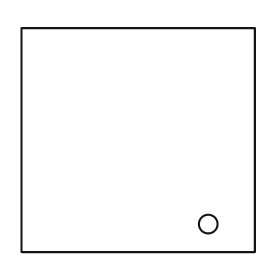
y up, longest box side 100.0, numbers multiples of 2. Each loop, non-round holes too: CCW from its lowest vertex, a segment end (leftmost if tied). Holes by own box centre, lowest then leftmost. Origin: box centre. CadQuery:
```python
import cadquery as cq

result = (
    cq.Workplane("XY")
    .moveTo(-50.0, -48.0)
    .lineTo(50.0, -48.0)
    .lineTo(50.0, 48.0)
    .lineTo(-50.0, 48.0)
    .close()
    .moveTo(30.0, -36.0)
    .circle(4.0)
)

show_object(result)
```